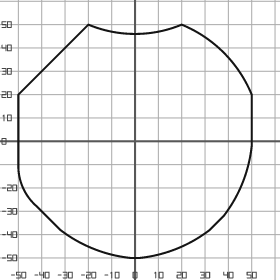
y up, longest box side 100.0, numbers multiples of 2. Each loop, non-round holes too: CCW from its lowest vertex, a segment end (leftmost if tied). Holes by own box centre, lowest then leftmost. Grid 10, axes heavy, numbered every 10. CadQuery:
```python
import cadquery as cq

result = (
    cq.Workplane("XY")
    .moveTo(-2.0, -50.0)
    .lineTo(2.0, -50.0)
    .threePointArc((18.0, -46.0), (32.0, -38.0))
    .lineTo(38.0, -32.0)
    .threePointArc((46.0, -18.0), (50.0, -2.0))
    .lineTo(50.0, 20.0)
    .threePointArc((38.0, 38.0), (20.0, 50.0))
    .threePointArc((0.0, 46.0), (-20.0, 50.0))
    .lineTo(-50.0, 20.0)
    .lineTo(-50.0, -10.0)
    .threePointArc((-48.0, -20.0), (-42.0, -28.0))
    .lineTo(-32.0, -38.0)
    .threePointArc((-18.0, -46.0), (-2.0, -50.0))
    .close()
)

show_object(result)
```